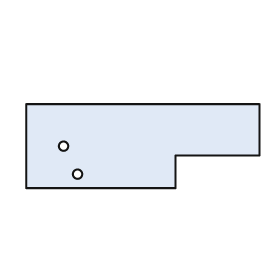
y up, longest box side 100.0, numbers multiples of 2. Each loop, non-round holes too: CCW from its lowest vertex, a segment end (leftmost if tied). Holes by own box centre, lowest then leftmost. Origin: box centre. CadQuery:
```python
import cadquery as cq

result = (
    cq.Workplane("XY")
    .moveTo(-50.0, -18.0)
    .lineTo(14.0, -18.0)
    .lineTo(14.0, -4.0)
    .lineTo(50.0, -4.0)
    .lineTo(50.0, 18.0)
    .lineTo(-50.0, 18.0)
    .close()
    .moveTo(-28.0, -12.0)
    .circle(2.0)
    .moveTo(-34.0, 0.0)
    .circle(2.0)
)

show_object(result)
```